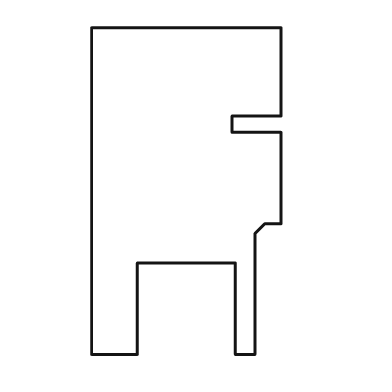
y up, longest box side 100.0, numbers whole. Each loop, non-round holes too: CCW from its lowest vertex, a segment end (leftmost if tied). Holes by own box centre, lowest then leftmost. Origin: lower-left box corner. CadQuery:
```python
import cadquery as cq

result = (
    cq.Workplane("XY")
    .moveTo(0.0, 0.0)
    .lineTo(14.0, 0.0)
    .lineTo(14.0, 28.0)
    .lineTo(44.0, 28.0)
    .lineTo(44.0, 0.0)
    .lineTo(50.0, 0.0)
    .lineTo(50.0, 37.0)
    .lineTo(53.0, 40.0)
    .lineTo(58.0, 40.0)
    .lineTo(58.0, 68.0)
    .lineTo(43.0, 68.0)
    .lineTo(43.0, 73.0)
    .lineTo(58.0, 73.0)
    .lineTo(58.0, 100.0)
    .lineTo(0.0, 100.0)
    .close()
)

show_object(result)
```